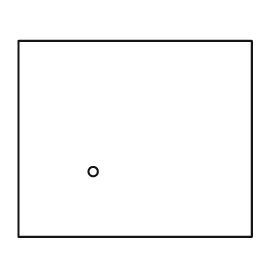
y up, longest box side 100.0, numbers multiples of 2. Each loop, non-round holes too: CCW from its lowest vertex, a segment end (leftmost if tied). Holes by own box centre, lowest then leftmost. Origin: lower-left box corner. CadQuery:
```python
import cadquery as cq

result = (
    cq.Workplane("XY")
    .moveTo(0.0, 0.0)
    .lineTo(100.0, 0.0)
    .lineTo(100.0, 84.0)
    .lineTo(0.0, 84.0)
    .close()
    .moveTo(32.0, 28.0)
    .circle(2.0)
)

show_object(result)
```